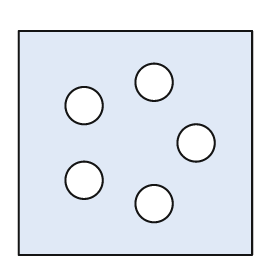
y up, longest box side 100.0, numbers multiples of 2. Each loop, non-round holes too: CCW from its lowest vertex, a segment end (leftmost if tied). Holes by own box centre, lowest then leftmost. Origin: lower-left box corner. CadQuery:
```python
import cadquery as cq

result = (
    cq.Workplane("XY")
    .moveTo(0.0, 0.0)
    .lineTo(100.0, 0.0)
    .lineTo(100.0, 96.0)
    .lineTo(0.0, 96.0)
    .close()
    .moveTo(58.0, 22.0)
    .circle(8.0)
    .moveTo(28.0, 32.0)
    .circle(8.0)
    .moveTo(76.0, 48.0)
    .circle(8.0)
    .moveTo(28.0, 64.0)
    .circle(8.0)
    .moveTo(58.0, 74.0)
    .circle(8.0)
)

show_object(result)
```